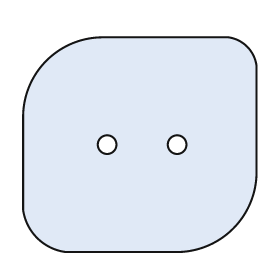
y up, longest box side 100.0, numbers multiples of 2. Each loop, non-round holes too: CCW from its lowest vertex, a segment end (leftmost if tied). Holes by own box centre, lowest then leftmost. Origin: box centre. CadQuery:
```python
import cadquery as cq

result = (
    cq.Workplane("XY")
    .moveTo(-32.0, -46.0)
    .lineTo(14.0, -46.0)
    .threePointArc((40.0, -36.0), (50.0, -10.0))
    .lineTo(50.0, 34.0)
    .threePointArc((46.0, 42.0), (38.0, 46.0))
    .lineTo(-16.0, 46.0)
    .threePointArc((-40.0, 36.0), (-50.0, 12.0))
    .lineTo(-50.0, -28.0)
    .threePointArc((-44.0, -40.0), (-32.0, -46.0))
    .close()
    .moveTo(-14.0, 0.0)
    .circle(4.0)
    .moveTo(16.0, 0.0)
    .circle(4.0)
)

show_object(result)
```